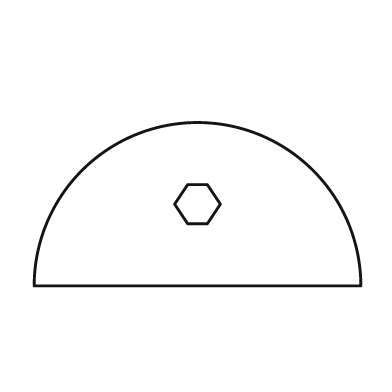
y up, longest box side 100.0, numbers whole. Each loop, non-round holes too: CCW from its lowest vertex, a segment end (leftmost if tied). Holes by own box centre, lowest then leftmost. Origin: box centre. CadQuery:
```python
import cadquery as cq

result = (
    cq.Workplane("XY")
    .moveTo(-50.0, -25.0)
    .lineTo(50.0, -25.0)
    .threePointArc((0.0, 25.0), (-50.0, -25.0))
    .close()
    .moveTo(-3.0, -6.0)
    .lineTo(3.0, -6.0)
    .lineTo(7.0, 0.0)
    .lineTo(3.0, 6.0)
    .lineTo(-3.0, 6.0)
    .lineTo(-7.0, 0.0)
    .close()
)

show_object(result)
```